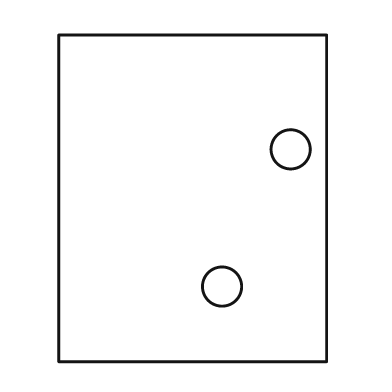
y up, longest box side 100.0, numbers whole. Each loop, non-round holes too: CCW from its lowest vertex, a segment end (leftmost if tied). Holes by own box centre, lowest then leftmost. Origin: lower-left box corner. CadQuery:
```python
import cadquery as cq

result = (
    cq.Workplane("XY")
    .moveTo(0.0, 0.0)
    .lineTo(82.0, 0.0)
    .lineTo(82.0, 100.0)
    .lineTo(0.0, 100.0)
    .close()
    .moveTo(50.0, 23.0)
    .circle(6.0)
    .moveTo(71.0, 65.0)
    .circle(6.0)
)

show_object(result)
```